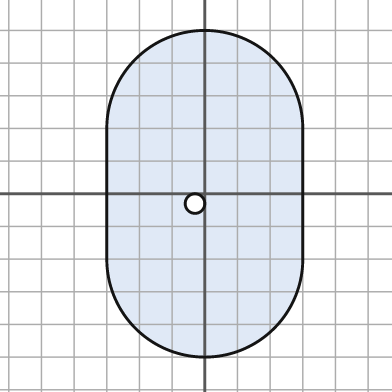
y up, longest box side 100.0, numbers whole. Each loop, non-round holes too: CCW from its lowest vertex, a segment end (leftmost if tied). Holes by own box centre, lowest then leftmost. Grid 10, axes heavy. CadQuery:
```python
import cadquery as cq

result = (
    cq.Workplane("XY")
    .moveTo(-30.0, -20.0)
    .threePointArc((0.0, -50.0), (30.0, -20.0))
    .lineTo(30.0, 20.0)
    .threePointArc((0.0, 50.0), (-30.0, 20.0))
    .close()
    .moveTo(-3.0, -3.0)
    .circle(3.0)
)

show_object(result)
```